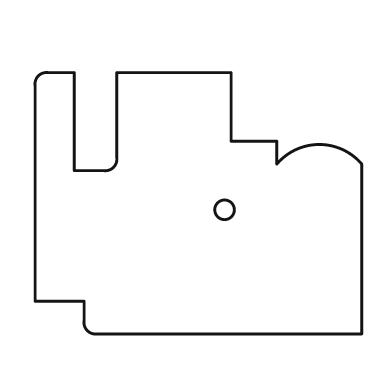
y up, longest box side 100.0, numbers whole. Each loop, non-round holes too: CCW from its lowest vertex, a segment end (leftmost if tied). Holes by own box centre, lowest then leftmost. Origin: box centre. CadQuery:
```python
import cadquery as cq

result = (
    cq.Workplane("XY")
    .moveTo(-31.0, -40.0)
    .lineTo(50.0, -40.0)
    .lineTo(50.0, 12.0)
    .threePointArc((37.0, 18.0), (24.0, 12.0))
    .lineTo(24.0, 19.0)
    .lineTo(10.0, 19.0)
    .lineTo(10.0, 40.0)
    .lineTo(-25.0, 40.0)
    .lineTo(-25.0, 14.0)
    .threePointArc((-26.0, 11.0), (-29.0, 10.0))
    .lineTo(-38.0, 10.0)
    .lineTo(-38.0, 40.0)
    .lineTo(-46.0, 40.0)
    .threePointArc((-49.0, 39.0), (-50.0, 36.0))
    .lineTo(-50.0, -30.0)
    .lineTo(-35.0, -30.0)
    .lineTo(-35.0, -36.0)
    .threePointArc((-34.0, -39.0), (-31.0, -40.0))
    .close()
    .moveTo(8.0, -2.0)
    .circle(3.0)
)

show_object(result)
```